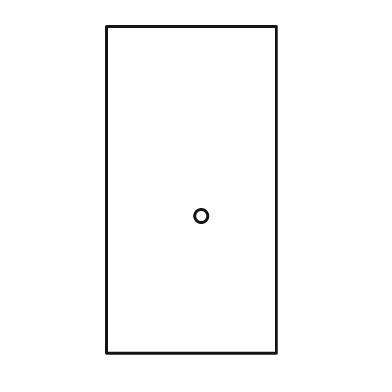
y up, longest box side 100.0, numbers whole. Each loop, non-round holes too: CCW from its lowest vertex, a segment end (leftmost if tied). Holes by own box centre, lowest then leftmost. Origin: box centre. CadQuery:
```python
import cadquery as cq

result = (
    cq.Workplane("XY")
    .moveTo(-26.0, -50.0)
    .lineTo(26.0, -50.0)
    .lineTo(26.0, 50.0)
    .lineTo(-26.0, 50.0)
    .close()
    .moveTo(3.0, -8.0)
    .circle(2.0)
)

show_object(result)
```